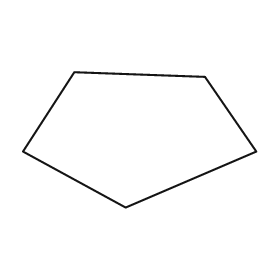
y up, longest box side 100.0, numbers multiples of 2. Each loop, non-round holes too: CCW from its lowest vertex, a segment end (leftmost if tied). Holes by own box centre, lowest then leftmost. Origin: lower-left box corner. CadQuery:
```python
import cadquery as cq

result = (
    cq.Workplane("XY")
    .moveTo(44.0, 0.0)
    .lineTo(100.0, 24.0)
    .lineTo(78.0, 56.0)
    .lineTo(22.0, 58.0)
    .lineTo(0.0, 24.0)
    .close()
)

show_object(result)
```